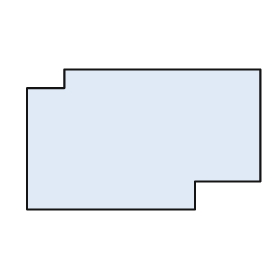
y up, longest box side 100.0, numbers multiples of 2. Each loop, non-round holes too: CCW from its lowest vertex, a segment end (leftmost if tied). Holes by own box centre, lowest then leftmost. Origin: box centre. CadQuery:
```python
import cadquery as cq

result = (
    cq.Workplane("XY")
    .moveTo(-50.0, -30.0)
    .lineTo(22.0, -30.0)
    .lineTo(22.0, -18.0)
    .lineTo(50.0, -18.0)
    .lineTo(50.0, 30.0)
    .lineTo(-34.0, 30.0)
    .lineTo(-34.0, 22.0)
    .lineTo(-50.0, 22.0)
    .close()
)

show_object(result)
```